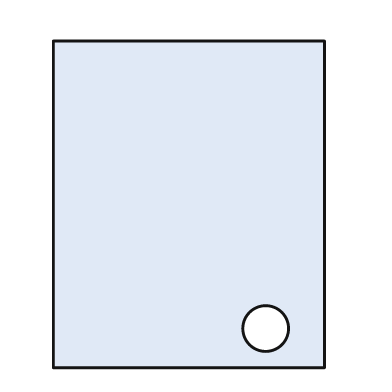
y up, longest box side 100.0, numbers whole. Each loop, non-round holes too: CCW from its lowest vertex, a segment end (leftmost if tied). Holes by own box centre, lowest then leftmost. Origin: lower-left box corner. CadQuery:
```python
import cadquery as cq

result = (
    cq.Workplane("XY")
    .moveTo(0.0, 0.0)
    .lineTo(83.0, 0.0)
    .lineTo(83.0, 100.0)
    .lineTo(0.0, 100.0)
    .close()
    .moveTo(65.0, 12.0)
    .circle(7.0)
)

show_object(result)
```